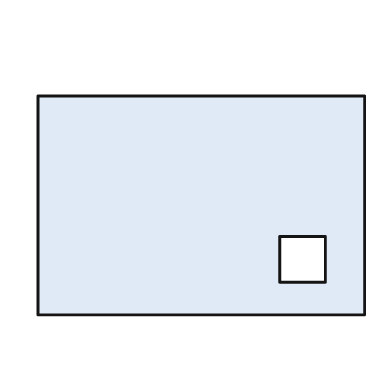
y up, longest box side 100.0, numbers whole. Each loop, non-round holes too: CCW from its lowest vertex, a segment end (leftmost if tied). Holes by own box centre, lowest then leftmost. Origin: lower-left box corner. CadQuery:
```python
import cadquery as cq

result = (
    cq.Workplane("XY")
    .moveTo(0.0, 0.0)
    .lineTo(100.0, 0.0)
    .lineTo(100.0, 67.0)
    .lineTo(0.0, 67.0)
    .close()
    .moveTo(74.0, 10.0)
    .lineTo(88.0, 10.0)
    .lineTo(88.0, 24.0)
    .lineTo(74.0, 24.0)
    .close()
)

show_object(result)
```